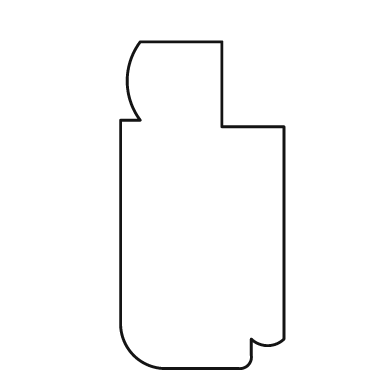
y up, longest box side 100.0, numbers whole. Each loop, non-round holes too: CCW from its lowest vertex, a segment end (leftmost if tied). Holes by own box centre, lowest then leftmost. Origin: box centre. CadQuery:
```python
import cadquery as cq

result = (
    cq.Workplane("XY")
    .moveTo(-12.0, -50.0)
    .lineTo(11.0, -50.0)
    .threePointArc((14.0, -49.0), (15.0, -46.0))
    .lineTo(15.0, -41.0)
    .threePointArc((20.0, -43.0), (25.0, -41.0))
    .lineTo(25.0, 24.0)
    .lineTo(6.0, 24.0)
    .lineTo(6.0, 50.0)
    .lineTo(-19.0, 50.0)
    .threePointArc((-23.0, 38.0), (-19.0, 26.0))
    .lineTo(-25.0, 26.0)
    .lineTo(-25.0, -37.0)
    .threePointArc((-21.0, -46.0), (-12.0, -50.0))
    .close()
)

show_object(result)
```